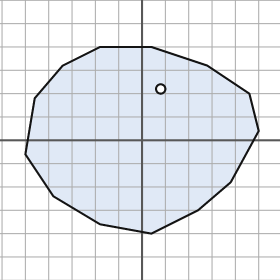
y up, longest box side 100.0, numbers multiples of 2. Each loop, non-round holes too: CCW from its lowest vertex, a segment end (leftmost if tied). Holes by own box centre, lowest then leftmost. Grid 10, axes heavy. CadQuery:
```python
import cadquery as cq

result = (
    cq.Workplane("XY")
    .moveTo(4.0, -40.0)
    .lineTo(24.0, -30.0)
    .lineTo(38.0, -18.0)
    .lineTo(50.0, 4.0)
    .lineTo(46.0, 20.0)
    .lineTo(28.0, 32.0)
    .lineTo(4.0, 40.0)
    .lineTo(-18.0, 40.0)
    .lineTo(-34.0, 32.0)
    .lineTo(-46.0, 18.0)
    .lineTo(-50.0, -6.0)
    .lineTo(-38.0, -24.0)
    .lineTo(-18.0, -36.0)
    .close()
    .moveTo(8.0, 22.0)
    .circle(2.0)
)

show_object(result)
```